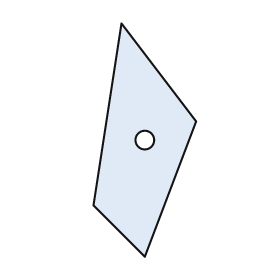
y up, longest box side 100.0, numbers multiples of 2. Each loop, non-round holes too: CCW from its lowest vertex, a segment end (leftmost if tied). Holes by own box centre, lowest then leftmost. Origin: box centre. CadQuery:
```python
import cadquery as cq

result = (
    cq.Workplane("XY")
    .moveTo(0.0, -50.0)
    .lineTo(22.0, 8.0)
    .lineTo(-10.0, 50.0)
    .lineTo(-22.0, -28.0)
    .close()
    .moveTo(0.0, 0.0)
    .circle(4.0)
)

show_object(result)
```